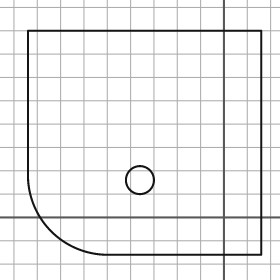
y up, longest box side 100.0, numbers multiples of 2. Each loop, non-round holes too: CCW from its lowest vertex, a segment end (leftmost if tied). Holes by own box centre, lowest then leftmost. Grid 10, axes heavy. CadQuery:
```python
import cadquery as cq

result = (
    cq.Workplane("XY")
    .moveTo(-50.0, -16.0)
    .lineTo(16.0, -16.0)
    .lineTo(16.0, 80.0)
    .lineTo(-84.0, 80.0)
    .lineTo(-84.0, 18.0)
    .threePointArc((-74.0, -6.0), (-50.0, -16.0))
    .close()
    .moveTo(-36.0, 16.0)
    .circle(6.0)
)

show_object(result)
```